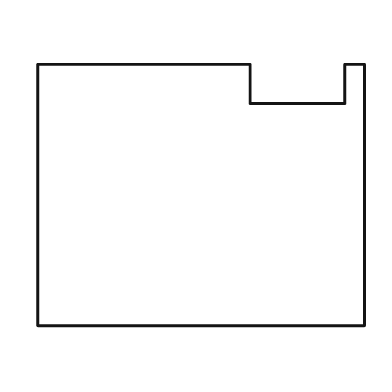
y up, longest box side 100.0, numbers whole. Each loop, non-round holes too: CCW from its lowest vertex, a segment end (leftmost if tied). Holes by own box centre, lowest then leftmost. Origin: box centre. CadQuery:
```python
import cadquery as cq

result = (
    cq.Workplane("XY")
    .moveTo(-50.0, -40.0)
    .lineTo(50.0, -40.0)
    .lineTo(50.0, 40.0)
    .lineTo(44.0, 40.0)
    .lineTo(44.0, 28.0)
    .lineTo(15.0, 28.0)
    .lineTo(15.0, 40.0)
    .lineTo(-50.0, 40.0)
    .close()
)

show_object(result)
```